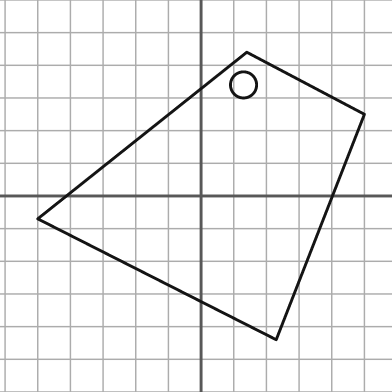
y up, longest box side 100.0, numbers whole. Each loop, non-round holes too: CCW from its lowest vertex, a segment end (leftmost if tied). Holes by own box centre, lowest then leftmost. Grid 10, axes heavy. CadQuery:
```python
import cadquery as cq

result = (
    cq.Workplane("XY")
    .moveTo(23.0, -44.0)
    .lineTo(50.0, 25.0)
    .lineTo(14.0, 44.0)
    .lineTo(-50.0, -7.0)
    .close()
    .moveTo(13.0, 34.0)
    .circle(4.0)
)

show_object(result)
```